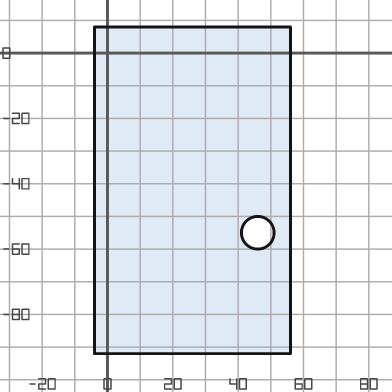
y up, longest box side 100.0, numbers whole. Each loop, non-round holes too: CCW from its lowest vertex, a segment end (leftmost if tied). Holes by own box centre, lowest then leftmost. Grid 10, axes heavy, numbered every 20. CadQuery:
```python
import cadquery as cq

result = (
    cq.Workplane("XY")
    .moveTo(-4.0, -92.0)
    .lineTo(56.0, -92.0)
    .lineTo(56.0, 8.0)
    .lineTo(-4.0, 8.0)
    .close()
    .moveTo(46.0, -55.0)
    .circle(5.0)
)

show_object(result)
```